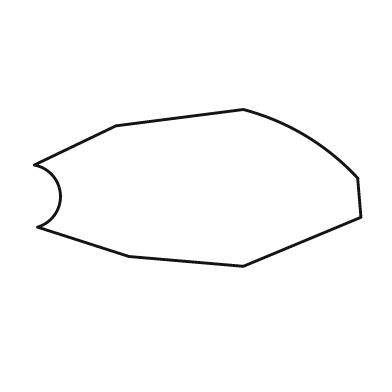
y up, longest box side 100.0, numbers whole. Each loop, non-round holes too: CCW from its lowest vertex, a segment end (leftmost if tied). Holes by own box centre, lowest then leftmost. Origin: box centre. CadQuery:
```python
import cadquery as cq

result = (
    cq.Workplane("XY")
    .moveTo(14.0, -24.0)
    .lineTo(50.0, -9.0)
    .lineTo(49.0, 3.0)
    .threePointArc((33.0, 16.0), (14.0, 24.0))
    .lineTo(-25.0, 19.0)
    .lineTo(-50.0, 7.0)
    .threePointArc((-42.0, -2.0), (-49.0, -12.0))
    .lineTo(-21.0, -21.0)
    .close()
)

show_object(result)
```